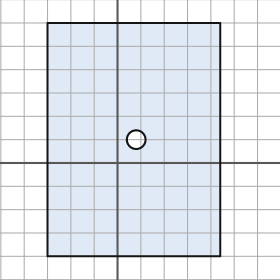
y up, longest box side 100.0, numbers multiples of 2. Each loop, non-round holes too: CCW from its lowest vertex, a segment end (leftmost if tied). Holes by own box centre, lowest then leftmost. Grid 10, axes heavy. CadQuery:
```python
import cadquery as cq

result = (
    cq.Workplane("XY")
    .moveTo(-30.0, -40.0)
    .lineTo(44.0, -40.0)
    .lineTo(44.0, 60.0)
    .lineTo(-30.0, 60.0)
    .close()
    .moveTo(8.0, 10.0)
    .circle(4.0)
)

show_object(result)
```